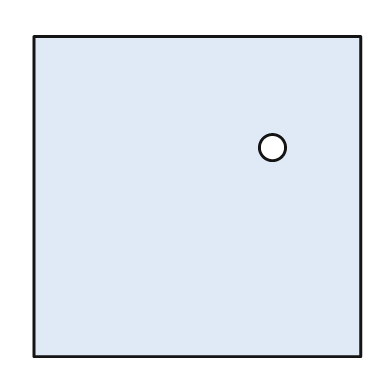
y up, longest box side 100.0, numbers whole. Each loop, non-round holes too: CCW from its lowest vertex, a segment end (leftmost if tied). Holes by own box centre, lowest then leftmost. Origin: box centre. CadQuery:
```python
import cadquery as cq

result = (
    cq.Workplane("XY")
    .moveTo(-50.0, -49.0)
    .lineTo(50.0, -49.0)
    .lineTo(50.0, 49.0)
    .lineTo(-50.0, 49.0)
    .close()
    .moveTo(23.0, 15.0)
    .circle(4.0)
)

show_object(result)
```